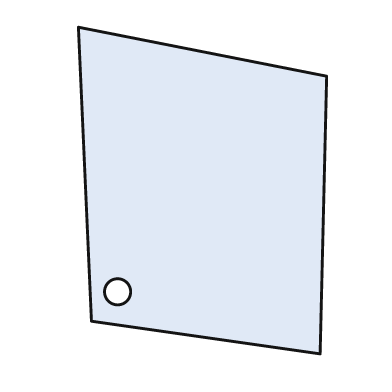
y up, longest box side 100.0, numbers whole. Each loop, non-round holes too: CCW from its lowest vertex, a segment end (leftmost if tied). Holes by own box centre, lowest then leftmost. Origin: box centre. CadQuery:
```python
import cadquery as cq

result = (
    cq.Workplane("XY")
    .moveTo(36.0, -50.0)
    .lineTo(38.0, 35.0)
    .lineTo(-38.0, 50.0)
    .lineTo(-34.0, -40.0)
    .close()
    .moveTo(-26.0, -31.0)
    .circle(4.0)
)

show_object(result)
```